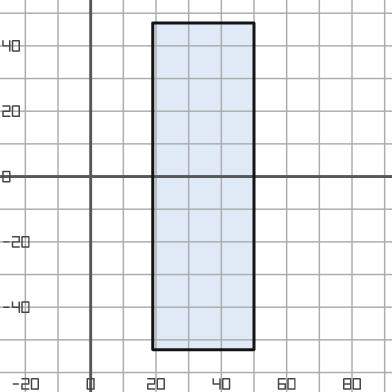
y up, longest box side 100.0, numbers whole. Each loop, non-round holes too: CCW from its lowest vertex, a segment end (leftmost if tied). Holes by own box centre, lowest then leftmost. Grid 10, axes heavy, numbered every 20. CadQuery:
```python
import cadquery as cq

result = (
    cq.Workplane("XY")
    .moveTo(19.0, -53.0)
    .lineTo(50.0, -53.0)
    .lineTo(50.0, 47.0)
    .lineTo(19.0, 47.0)
    .close()
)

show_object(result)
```